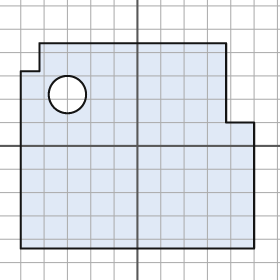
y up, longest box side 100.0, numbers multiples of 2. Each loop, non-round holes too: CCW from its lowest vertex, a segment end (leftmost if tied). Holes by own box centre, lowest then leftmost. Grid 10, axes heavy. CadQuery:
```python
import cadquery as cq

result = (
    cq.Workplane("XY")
    .moveTo(-50.0, -44.0)
    .lineTo(50.0, -44.0)
    .lineTo(50.0, 10.0)
    .lineTo(38.0, 10.0)
    .lineTo(38.0, 44.0)
    .lineTo(-42.0, 44.0)
    .lineTo(-42.0, 32.0)
    .lineTo(-50.0, 32.0)
    .close()
    .moveTo(-30.0, 22.0)
    .circle(8.0)
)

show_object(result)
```